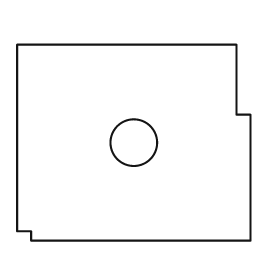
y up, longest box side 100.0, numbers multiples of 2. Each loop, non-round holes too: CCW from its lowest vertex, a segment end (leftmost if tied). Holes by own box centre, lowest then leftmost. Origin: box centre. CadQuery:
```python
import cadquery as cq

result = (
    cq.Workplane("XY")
    .moveTo(-44.0, -42.0)
    .lineTo(50.0, -42.0)
    .lineTo(50.0, 12.0)
    .lineTo(44.0, 12.0)
    .lineTo(44.0, 42.0)
    .lineTo(-50.0, 42.0)
    .lineTo(-50.0, -38.0)
    .lineTo(-44.0, -38.0)
    .close()
    .moveTo(0.0, 0.0)
    .circle(10.0)
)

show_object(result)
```